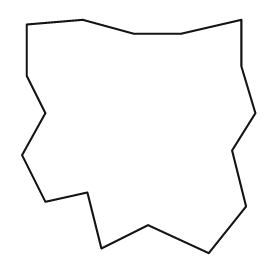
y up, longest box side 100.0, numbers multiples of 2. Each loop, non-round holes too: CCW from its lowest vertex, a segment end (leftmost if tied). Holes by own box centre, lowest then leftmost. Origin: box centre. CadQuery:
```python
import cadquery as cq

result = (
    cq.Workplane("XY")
    .moveTo(30.0, -50.0)
    .lineTo(46.0, -30.0)
    .lineTo(40.0, -6.0)
    .lineTo(50.0, 10.0)
    .lineTo(44.0, 30.0)
    .lineTo(44.0, 50.0)
    .lineTo(18.0, 44.0)
    .lineTo(-2.0, 44.0)
    .lineTo(-24.0, 50.0)
    .lineTo(-48.0, 48.0)
    .lineTo(-48.0, 26.0)
    .lineTo(-40.0, 10.0)
    .lineTo(-50.0, -8.0)
    .lineTo(-40.0, -28.0)
    .lineTo(-22.0, -24.0)
    .lineTo(-16.0, -48.0)
    .lineTo(4.0, -38.0)
    .close()
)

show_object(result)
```